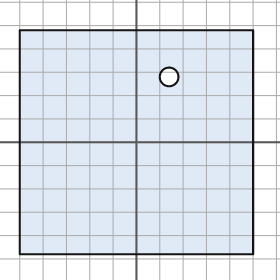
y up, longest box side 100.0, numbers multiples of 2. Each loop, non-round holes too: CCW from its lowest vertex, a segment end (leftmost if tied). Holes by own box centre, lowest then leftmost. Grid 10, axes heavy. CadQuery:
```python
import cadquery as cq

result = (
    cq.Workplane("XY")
    .moveTo(-50.0, -48.0)
    .lineTo(50.0, -48.0)
    .lineTo(50.0, 48.0)
    .lineTo(-50.0, 48.0)
    .close()
    .moveTo(14.0, 28.0)
    .circle(4.0)
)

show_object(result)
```